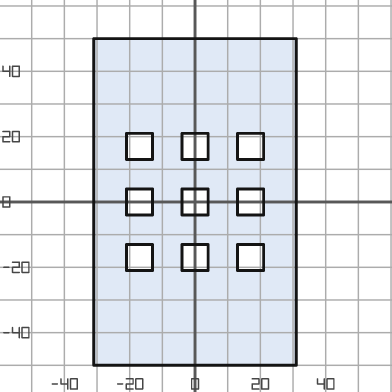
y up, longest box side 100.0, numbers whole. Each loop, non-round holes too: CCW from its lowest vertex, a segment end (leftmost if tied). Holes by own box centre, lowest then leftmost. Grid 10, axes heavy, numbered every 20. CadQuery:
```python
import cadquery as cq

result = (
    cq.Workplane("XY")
    .moveTo(-31.0, -50.0)
    .lineTo(31.0, -50.0)
    .lineTo(31.0, 50.0)
    .lineTo(-31.0, 50.0)
    .close()
    .moveTo(-21.0, -21.0)
    .lineTo(-13.0, -21.0)
    .lineTo(-13.0, -13.0)
    .lineTo(-21.0, -13.0)
    .close()
    .moveTo(-4.0, -21.0)
    .lineTo(4.0, -21.0)
    .lineTo(4.0, -13.0)
    .lineTo(-4.0, -13.0)
    .close()
    .moveTo(13.0, -21.0)
    .lineTo(21.0, -21.0)
    .lineTo(21.0, -13.0)
    .lineTo(13.0, -13.0)
    .close()
    .moveTo(-21.0, -4.0)
    .lineTo(-13.0, -4.0)
    .lineTo(-13.0, 4.0)
    .lineTo(-21.0, 4.0)
    .close()
    .moveTo(-4.0, -4.0)
    .lineTo(4.0, -4.0)
    .lineTo(4.0, 4.0)
    .lineTo(-4.0, 4.0)
    .close()
    .moveTo(13.0, -4.0)
    .lineTo(21.0, -4.0)
    .lineTo(21.0, 4.0)
    .lineTo(13.0, 4.0)
    .close()
    .moveTo(-21.0, 13.0)
    .lineTo(-13.0, 13.0)
    .lineTo(-13.0, 21.0)
    .lineTo(-21.0, 21.0)
    .close()
    .moveTo(-4.0, 13.0)
    .lineTo(4.0, 13.0)
    .lineTo(4.0, 21.0)
    .lineTo(-4.0, 21.0)
    .close()
    .moveTo(13.0, 13.0)
    .lineTo(21.0, 13.0)
    .lineTo(21.0, 21.0)
    .lineTo(13.0, 21.0)
    .close()
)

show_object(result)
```